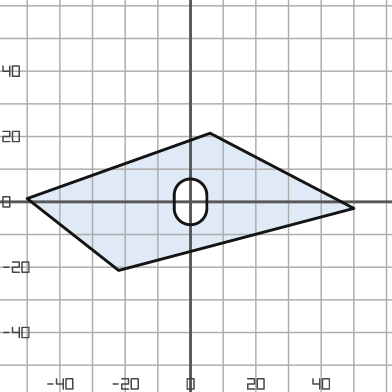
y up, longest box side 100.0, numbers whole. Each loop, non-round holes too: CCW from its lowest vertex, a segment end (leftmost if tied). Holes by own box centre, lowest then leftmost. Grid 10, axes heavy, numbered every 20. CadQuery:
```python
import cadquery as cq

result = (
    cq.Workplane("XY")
    .moveTo(-22.0, -21.0)
    .lineTo(50.0, -2.0)
    .lineTo(6.0, 21.0)
    .lineTo(-50.0, 1.0)
    .close()
    .moveTo(-5.0, -2.0)
    .threePointArc((0.0, -7.0), (5.0, -2.0))
    .lineTo(5.0, 2.0)
    .threePointArc((0.0, 7.0), (-5.0, 2.0))
    .close()
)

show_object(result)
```